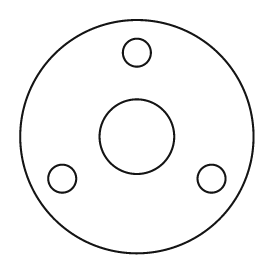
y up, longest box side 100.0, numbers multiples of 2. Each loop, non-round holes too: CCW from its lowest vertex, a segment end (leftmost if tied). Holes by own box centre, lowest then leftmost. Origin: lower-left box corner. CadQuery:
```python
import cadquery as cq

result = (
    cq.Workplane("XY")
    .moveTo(50.0, 50.0)
    .circle(50.0)
    .moveTo(18.0, 32.0)
    .circle(6.0)
    .moveTo(82.0, 32.0)
    .circle(6.0)
    .moveTo(50.0, 50.0)
    .circle(16.0)
    .moveTo(50.0, 86.0)
    .circle(6.0)
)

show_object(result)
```